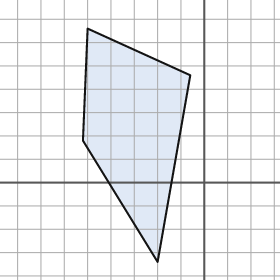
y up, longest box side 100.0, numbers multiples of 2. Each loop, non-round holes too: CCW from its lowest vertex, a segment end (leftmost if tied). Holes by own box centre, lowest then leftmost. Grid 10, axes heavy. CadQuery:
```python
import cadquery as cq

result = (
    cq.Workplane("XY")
    .moveTo(-20.0, -34.0)
    .lineTo(-6.0, 46.0)
    .lineTo(-50.0, 66.0)
    .lineTo(-52.0, 18.0)
    .close()
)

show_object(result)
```